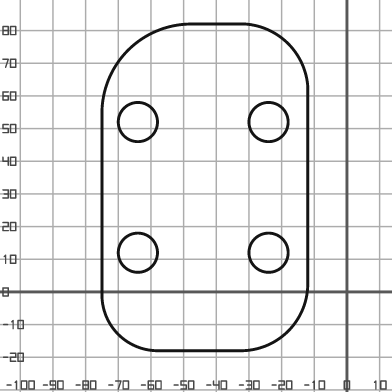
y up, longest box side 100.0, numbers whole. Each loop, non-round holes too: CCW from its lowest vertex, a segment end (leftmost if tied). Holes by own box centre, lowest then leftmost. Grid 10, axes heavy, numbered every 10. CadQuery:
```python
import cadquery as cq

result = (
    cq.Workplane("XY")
    .moveTo(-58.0, -18.0)
    .lineTo(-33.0, -18.0)
    .threePointArc((-18.0, -12.0), (-12.0, 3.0))
    .lineTo(-12.0, 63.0)
    .threePointArc((-18.0, 76.0), (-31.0, 82.0))
    .lineTo(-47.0, 82.0)
    .threePointArc((-67.0, 74.0), (-75.0, 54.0))
    .lineTo(-75.0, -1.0)
    .threePointArc((-70.0, -13.0), (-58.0, -18.0))
    .close()
    .moveTo(-64.0, 12.0)
    .circle(6.0)
    .moveTo(-24.0, 12.0)
    .circle(6.0)
    .moveTo(-64.0, 52.0)
    .circle(6.0)
    .moveTo(-24.0, 52.0)
    .circle(6.0)
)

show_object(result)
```